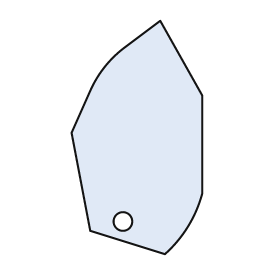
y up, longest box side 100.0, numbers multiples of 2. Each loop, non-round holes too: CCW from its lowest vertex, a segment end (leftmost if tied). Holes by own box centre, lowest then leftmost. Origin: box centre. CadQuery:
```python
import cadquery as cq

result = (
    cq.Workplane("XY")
    .moveTo(12.0, -50.0)
    .threePointArc((22.0, -38.0), (28.0, -24.0))
    .lineTo(28.0, 18.0)
    .lineTo(10.0, 50.0)
    .lineTo(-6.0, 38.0)
    .threePointArc((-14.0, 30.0), (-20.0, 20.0))
    .lineTo(-28.0, 2.0)
    .lineTo(-20.0, -40.0)
    .close()
    .moveTo(-6.0, -36.0)
    .circle(4.0)
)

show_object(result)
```